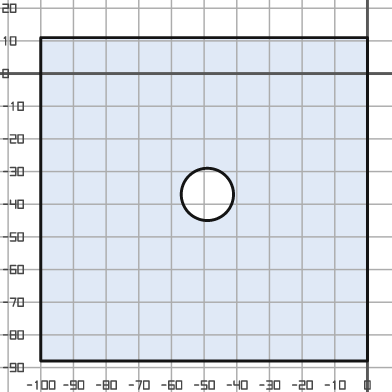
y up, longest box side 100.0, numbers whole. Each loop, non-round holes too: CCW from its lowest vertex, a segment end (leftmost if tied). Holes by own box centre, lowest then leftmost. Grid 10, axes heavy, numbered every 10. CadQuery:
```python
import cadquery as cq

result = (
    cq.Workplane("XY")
    .moveTo(-100.0, -88.0)
    .lineTo(0.0, -88.0)
    .lineTo(0.0, 11.0)
    .lineTo(-100.0, 11.0)
    .close()
    .moveTo(-49.0, -37.0)
    .circle(8.0)
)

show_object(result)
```